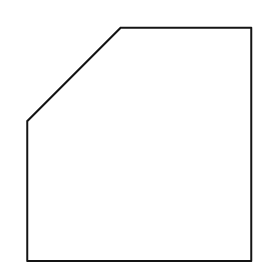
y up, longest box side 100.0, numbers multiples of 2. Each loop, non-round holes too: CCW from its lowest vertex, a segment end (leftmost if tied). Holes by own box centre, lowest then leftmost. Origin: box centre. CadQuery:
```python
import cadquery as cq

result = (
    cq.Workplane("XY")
    .moveTo(-48.0, -50.0)
    .lineTo(48.0, -50.0)
    .lineTo(48.0, 50.0)
    .lineTo(-8.0, 50.0)
    .lineTo(-48.0, 10.0)
    .close()
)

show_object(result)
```